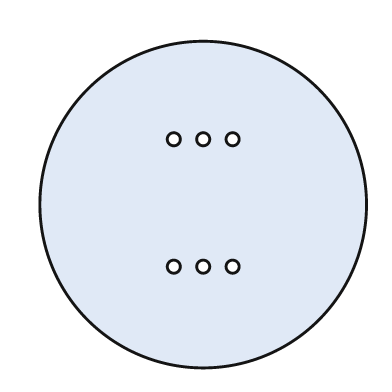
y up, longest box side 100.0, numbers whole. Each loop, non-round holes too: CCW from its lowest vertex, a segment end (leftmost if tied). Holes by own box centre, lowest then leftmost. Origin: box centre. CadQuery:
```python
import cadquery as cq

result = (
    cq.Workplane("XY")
    .moveTo(0.0, 0.0)
    .circle(50.0)
    .moveTo(-9.0, -19.0)
    .circle(2.0)
    .moveTo(0.0, -19.0)
    .circle(2.0)
    .moveTo(9.0, -19.0)
    .circle(2.0)
    .moveTo(-9.0, 20.0)
    .circle(2.0)
    .moveTo(0.0, 20.0)
    .circle(2.0)
    .moveTo(9.0, 20.0)
    .circle(2.0)
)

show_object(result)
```